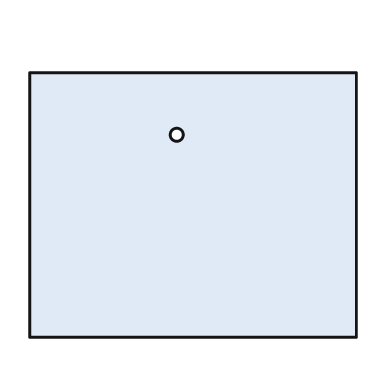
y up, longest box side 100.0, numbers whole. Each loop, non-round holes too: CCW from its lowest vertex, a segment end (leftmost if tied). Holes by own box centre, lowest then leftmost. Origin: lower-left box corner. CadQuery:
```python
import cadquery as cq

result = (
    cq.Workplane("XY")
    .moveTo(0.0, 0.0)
    .lineTo(100.0, 0.0)
    .lineTo(100.0, 81.0)
    .lineTo(0.0, 81.0)
    .close()
    .moveTo(45.0, 62.0)
    .circle(2.0)
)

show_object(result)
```